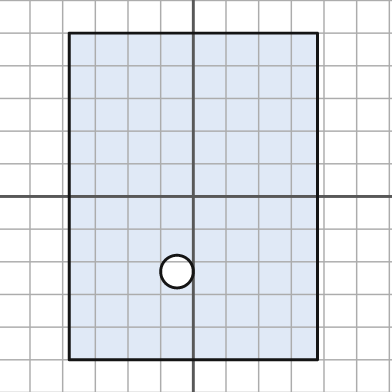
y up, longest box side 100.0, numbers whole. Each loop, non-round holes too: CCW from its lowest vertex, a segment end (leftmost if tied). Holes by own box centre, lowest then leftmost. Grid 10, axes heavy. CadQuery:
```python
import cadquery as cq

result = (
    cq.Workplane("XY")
    .moveTo(-38.0, -50.0)
    .lineTo(38.0, -50.0)
    .lineTo(38.0, 50.0)
    .lineTo(-38.0, 50.0)
    .close()
    .moveTo(-5.0, -23.0)
    .circle(5.0)
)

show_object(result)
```